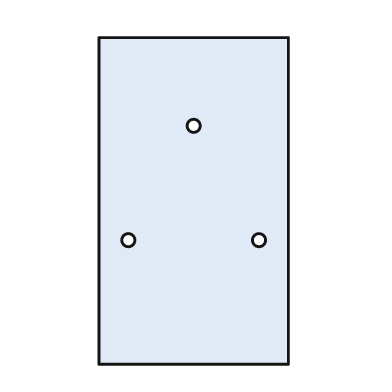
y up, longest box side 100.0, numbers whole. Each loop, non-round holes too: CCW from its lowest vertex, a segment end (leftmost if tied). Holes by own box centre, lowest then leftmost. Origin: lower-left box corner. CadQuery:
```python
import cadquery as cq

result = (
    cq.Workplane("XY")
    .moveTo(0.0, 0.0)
    .lineTo(58.0, 0.0)
    .lineTo(58.0, 100.0)
    .lineTo(0.0, 100.0)
    .close()
    .moveTo(9.0, 38.0)
    .circle(2.0)
    .moveTo(49.0, 38.0)
    .circle(2.0)
    .moveTo(29.0, 73.0)
    .circle(2.0)
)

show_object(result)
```